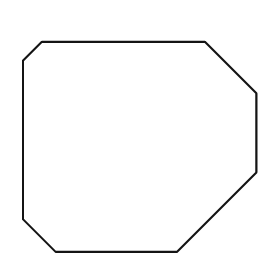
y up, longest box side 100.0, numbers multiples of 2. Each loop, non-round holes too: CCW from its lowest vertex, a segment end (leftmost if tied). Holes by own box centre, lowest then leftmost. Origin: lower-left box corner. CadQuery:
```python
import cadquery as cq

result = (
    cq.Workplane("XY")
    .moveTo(14.0, 0.0)
    .lineTo(66.0, 0.0)
    .lineTo(100.0, 34.0)
    .lineTo(100.0, 68.0)
    .lineTo(78.0, 90.0)
    .lineTo(8.0, 90.0)
    .lineTo(0.0, 82.0)
    .lineTo(0.0, 14.0)
    .close()
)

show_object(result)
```